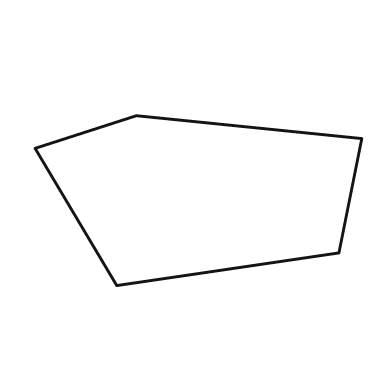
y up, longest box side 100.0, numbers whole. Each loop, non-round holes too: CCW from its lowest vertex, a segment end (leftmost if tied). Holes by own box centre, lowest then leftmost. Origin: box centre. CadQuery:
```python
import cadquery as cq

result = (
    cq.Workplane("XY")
    .moveTo(-25.0, -26.0)
    .lineTo(43.0, -16.0)
    .lineTo(50.0, 19.0)
    .lineTo(-19.0, 26.0)
    .lineTo(-50.0, 16.0)
    .close()
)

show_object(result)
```